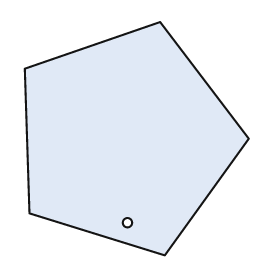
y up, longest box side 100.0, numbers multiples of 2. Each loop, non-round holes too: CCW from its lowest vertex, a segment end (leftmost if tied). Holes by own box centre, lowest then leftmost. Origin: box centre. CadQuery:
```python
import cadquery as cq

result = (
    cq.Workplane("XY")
    .moveTo(12.0, -50.0)
    .lineTo(48.0, 0.0)
    .lineTo(10.0, 50.0)
    .lineTo(-48.0, 30.0)
    .lineTo(-46.0, -32.0)
    .close()
    .moveTo(-4.0, -36.0)
    .circle(2.0)
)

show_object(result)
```